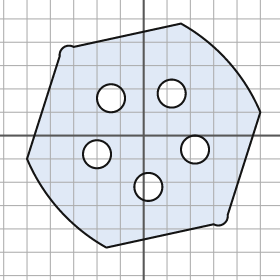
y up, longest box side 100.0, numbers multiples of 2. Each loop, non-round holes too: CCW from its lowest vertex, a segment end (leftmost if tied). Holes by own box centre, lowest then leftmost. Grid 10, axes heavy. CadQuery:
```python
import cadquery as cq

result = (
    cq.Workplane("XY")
    .moveTo(-16.0, -48.0)
    .lineTo(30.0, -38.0)
    .threePointArc((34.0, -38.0), (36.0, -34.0))
    .lineTo(50.0, 10.0)
    .threePointArc((36.0, 32.0), (16.0, 48.0))
    .lineTo(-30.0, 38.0)
    .threePointArc((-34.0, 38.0), (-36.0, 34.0))
    .lineTo(-50.0, -10.0)
    .threePointArc((-36.0, -32.0), (-16.0, -48.0))
    .close()
    .moveTo(2.0, -22.0)
    .circle(6.0)
    .moveTo(-20.0, -8.0)
    .circle(6.0)
    .moveTo(22.0, -6.0)
    .circle(6.0)
    .moveTo(-14.0, 16.0)
    .circle(6.0)
    .moveTo(12.0, 18.0)
    .circle(6.0)
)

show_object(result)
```